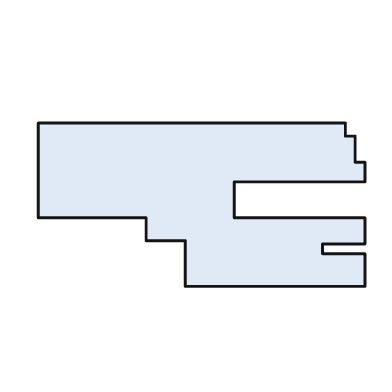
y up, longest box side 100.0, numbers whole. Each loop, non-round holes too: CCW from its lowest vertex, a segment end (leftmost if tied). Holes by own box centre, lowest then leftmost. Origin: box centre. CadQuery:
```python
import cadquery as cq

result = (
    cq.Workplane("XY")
    .moveTo(-5.0, -25.0)
    .lineTo(50.0, -25.0)
    .lineTo(50.0, -15.0)
    .lineTo(37.0, -15.0)
    .lineTo(37.0, -12.0)
    .lineTo(50.0, -12.0)
    .lineTo(50.0, -4.0)
    .lineTo(10.0, -4.0)
    .lineTo(10.0, 7.0)
    .lineTo(50.0, 7.0)
    .lineTo(50.0, 13.0)
    .lineTo(47.0, 13.0)
    .lineTo(47.0, 21.0)
    .lineTo(44.0, 21.0)
    .lineTo(44.0, 25.0)
    .lineTo(-50.0, 25.0)
    .lineTo(-50.0, -4.0)
    .lineTo(-17.0, -4.0)
    .lineTo(-17.0, -11.0)
    .lineTo(-5.0, -11.0)
    .close()
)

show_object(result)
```